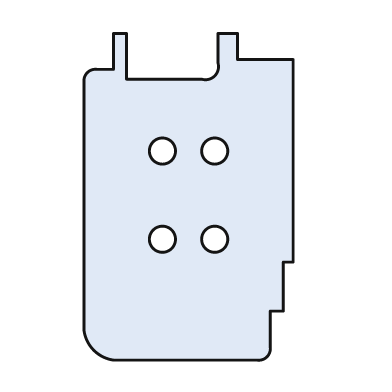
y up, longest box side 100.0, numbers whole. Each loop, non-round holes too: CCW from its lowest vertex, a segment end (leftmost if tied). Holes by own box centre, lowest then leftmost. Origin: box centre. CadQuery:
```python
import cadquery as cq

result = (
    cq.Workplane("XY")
    .moveTo(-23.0, -50.0)
    .lineTo(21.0, -50.0)
    .threePointArc((24.0, -49.0), (25.0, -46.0))
    .lineTo(25.0, -35.0)
    .lineTo(29.0, -35.0)
    .lineTo(29.0, -20.0)
    .lineTo(32.0, -20.0)
    .lineTo(32.0, 42.0)
    .lineTo(15.0, 42.0)
    .lineTo(15.0, 50.0)
    .lineTo(9.0, 50.0)
    .lineTo(9.0, 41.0)
    .threePointArc((8.0, 37.0), (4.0, 36.0))
    .lineTo(-19.0, 36.0)
    .lineTo(-19.0, 50.0)
    .lineTo(-23.0, 50.0)
    .lineTo(-23.0, 39.0)
    .lineTo(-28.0, 39.0)
    .threePointArc((-31.0, 38.0), (-32.0, 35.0))
    .lineTo(-32.0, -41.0)
    .threePointArc((-29.0, -47.0), (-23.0, -50.0))
    .close()
    .moveTo(-8.0, -13.0)
    .circle(4.0)
    .moveTo(8.0, -13.0)
    .circle(4.0)
    .moveTo(-8.0, 14.0)
    .circle(4.0)
    .moveTo(8.0, 14.0)
    .circle(4.0)
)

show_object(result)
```